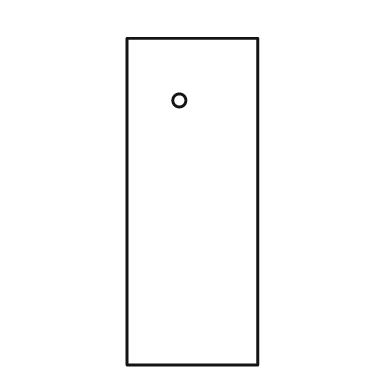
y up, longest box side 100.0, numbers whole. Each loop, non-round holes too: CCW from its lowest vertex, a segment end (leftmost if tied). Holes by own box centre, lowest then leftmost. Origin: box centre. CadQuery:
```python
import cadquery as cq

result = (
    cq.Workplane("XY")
    .moveTo(-20.0, -50.0)
    .lineTo(20.0, -50.0)
    .lineTo(20.0, 50.0)
    .lineTo(-20.0, 50.0)
    .close()
    .moveTo(-4.0, 31.0)
    .circle(2.0)
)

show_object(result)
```